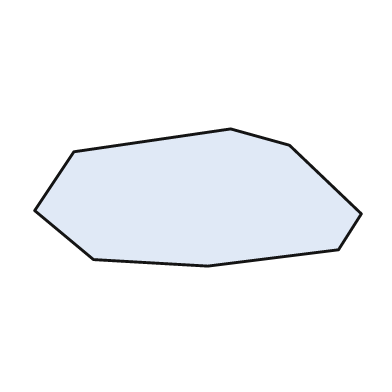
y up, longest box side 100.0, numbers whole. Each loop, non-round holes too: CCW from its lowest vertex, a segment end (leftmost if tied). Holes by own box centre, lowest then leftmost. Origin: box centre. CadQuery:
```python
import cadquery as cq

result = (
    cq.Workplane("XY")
    .moveTo(3.0, -21.0)
    .lineTo(43.0, -16.0)
    .lineTo(50.0, -5.0)
    .lineTo(28.0, 16.0)
    .lineTo(10.0, 21.0)
    .lineTo(-38.0, 14.0)
    .lineTo(-50.0, -4.0)
    .lineTo(-32.0, -19.0)
    .close()
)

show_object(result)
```